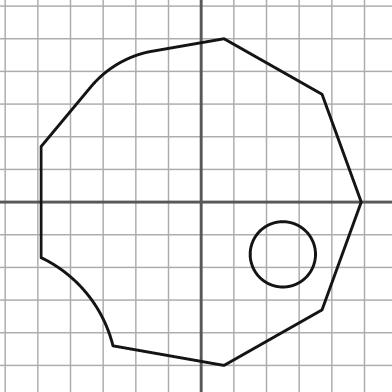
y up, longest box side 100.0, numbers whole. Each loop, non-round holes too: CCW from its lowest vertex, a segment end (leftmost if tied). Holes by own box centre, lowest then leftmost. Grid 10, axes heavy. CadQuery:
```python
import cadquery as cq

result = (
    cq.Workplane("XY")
    .moveTo(7.0, -50.0)
    .lineTo(37.0, -33.0)
    .lineTo(49.0, 0.0)
    .lineTo(37.0, 33.0)
    .lineTo(7.0, 50.0)
    .lineTo(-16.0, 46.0)
    .threePointArc((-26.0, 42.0), (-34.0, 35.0))
    .lineTo(-49.0, 17.0)
    .lineTo(-49.0, -17.0)
    .threePointArc((-35.0, -28.0), (-27.0, -44.0))
    .close()
    .moveTo(25.0, -16.0)
    .circle(10.0)
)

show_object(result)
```